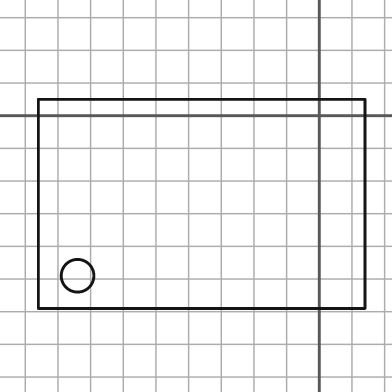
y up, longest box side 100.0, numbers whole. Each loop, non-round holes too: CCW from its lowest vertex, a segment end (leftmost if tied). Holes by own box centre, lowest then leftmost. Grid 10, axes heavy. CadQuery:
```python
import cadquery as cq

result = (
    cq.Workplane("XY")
    .moveTo(-86.0, -59.0)
    .lineTo(14.0, -59.0)
    .lineTo(14.0, 5.0)
    .lineTo(-86.0, 5.0)
    .close()
    .moveTo(-74.0, -49.0)
    .circle(5.0)
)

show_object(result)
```